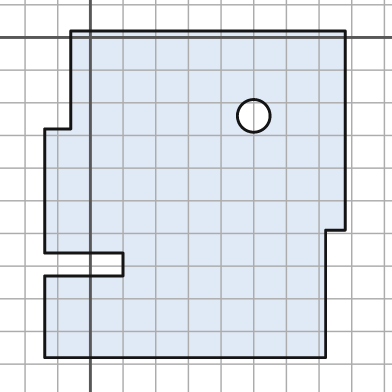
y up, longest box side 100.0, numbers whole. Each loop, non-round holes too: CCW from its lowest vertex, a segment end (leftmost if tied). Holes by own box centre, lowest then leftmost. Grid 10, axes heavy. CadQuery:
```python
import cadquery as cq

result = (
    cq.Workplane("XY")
    .moveTo(-14.0, -98.0)
    .lineTo(72.0, -98.0)
    .lineTo(72.0, -59.0)
    .lineTo(78.0, -59.0)
    .lineTo(78.0, 2.0)
    .lineTo(-6.0, 2.0)
    .lineTo(-6.0, -28.0)
    .lineTo(-14.0, -28.0)
    .lineTo(-14.0, -66.0)
    .lineTo(10.0, -66.0)
    .lineTo(10.0, -73.0)
    .lineTo(-14.0, -73.0)
    .close()
    .moveTo(50.0, -24.0)
    .circle(5.0)
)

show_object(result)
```